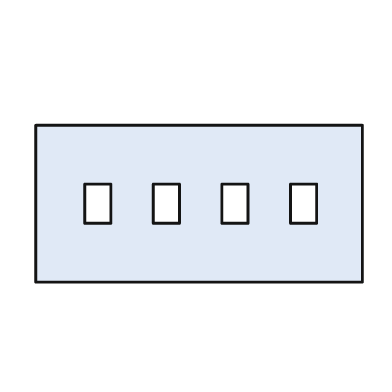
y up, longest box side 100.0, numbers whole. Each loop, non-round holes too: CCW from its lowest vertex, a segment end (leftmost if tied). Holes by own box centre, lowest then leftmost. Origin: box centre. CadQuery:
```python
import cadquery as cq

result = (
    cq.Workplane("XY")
    .moveTo(-50.0, -24.0)
    .lineTo(50.0, -24.0)
    .lineTo(50.0, 24.0)
    .lineTo(-50.0, 24.0)
    .close()
    .moveTo(-35.0, -6.0)
    .lineTo(-27.0, -6.0)
    .lineTo(-27.0, 6.0)
    .lineTo(-35.0, 6.0)
    .close()
    .moveTo(-14.0, -6.0)
    .lineTo(-6.0, -6.0)
    .lineTo(-6.0, 6.0)
    .lineTo(-14.0, 6.0)
    .close()
    .moveTo(7.0, -6.0)
    .lineTo(15.0, -6.0)
    .lineTo(15.0, 6.0)
    .lineTo(7.0, 6.0)
    .close()
    .moveTo(28.0, -6.0)
    .lineTo(36.0, -6.0)
    .lineTo(36.0, 6.0)
    .lineTo(28.0, 6.0)
    .close()
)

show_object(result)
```